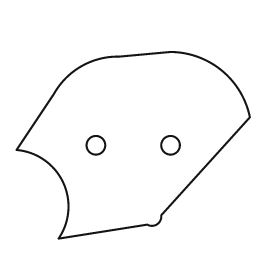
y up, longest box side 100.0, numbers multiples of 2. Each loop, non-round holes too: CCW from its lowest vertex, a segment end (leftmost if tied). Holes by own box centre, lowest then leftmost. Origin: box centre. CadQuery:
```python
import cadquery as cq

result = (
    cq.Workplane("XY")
    .moveTo(-32.0, -40.0)
    .lineTo(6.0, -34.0)
    .threePointArc((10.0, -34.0), (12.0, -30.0))
    .lineTo(50.0, 12.0)
    .threePointArc((38.0, 32.0), (16.0, 40.0))
    .lineTo(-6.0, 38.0)
    .threePointArc((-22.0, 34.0), (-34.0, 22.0))
    .lineTo(-50.0, -2.0)
    .threePointArc((-30.0, -16.0), (-32.0, -40.0))
    .close()
    .moveTo(-16.0, 0.0)
    .circle(4.0)
    .moveTo(16.0, 0.0)
    .circle(4.0)
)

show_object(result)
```